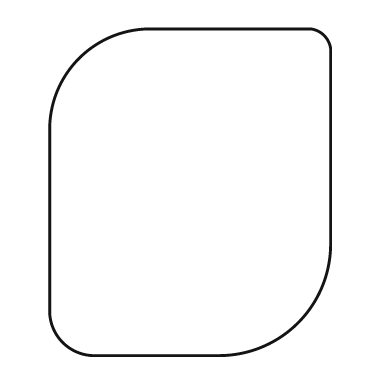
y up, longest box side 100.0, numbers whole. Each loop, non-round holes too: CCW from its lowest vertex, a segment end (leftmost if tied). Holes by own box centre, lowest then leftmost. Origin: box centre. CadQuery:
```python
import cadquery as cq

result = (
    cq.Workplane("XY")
    .moveTo(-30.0, -50.0)
    .lineTo(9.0, -50.0)
    .threePointArc((33.0, -40.0), (43.0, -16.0))
    .lineTo(43.0, 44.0)
    .threePointArc((41.0, 48.0), (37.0, 50.0))
    .lineTo(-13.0, 50.0)
    .threePointArc((-34.0, 41.0), (-43.0, 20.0))
    .lineTo(-43.0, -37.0)
    .threePointArc((-39.0, -46.0), (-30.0, -50.0))
    .close()
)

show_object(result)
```